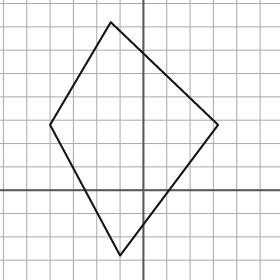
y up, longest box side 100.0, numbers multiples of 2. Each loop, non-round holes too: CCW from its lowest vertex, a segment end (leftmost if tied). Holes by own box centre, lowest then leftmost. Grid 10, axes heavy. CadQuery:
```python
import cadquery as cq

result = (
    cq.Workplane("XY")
    .moveTo(-10.0, -28.0)
    .lineTo(32.0, 28.0)
    .lineTo(-14.0, 72.0)
    .lineTo(-40.0, 28.0)
    .close()
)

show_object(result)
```